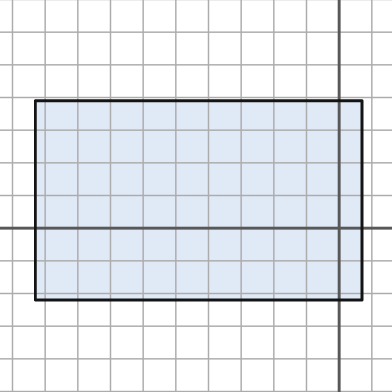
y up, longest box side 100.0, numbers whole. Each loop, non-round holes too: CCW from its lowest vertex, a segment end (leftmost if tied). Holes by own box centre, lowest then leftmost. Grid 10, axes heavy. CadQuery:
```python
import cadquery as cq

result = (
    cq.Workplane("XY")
    .moveTo(-93.0, -22.0)
    .lineTo(7.0, -22.0)
    .lineTo(7.0, 39.0)
    .lineTo(-93.0, 39.0)
    .close()
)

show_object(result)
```